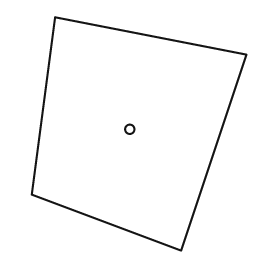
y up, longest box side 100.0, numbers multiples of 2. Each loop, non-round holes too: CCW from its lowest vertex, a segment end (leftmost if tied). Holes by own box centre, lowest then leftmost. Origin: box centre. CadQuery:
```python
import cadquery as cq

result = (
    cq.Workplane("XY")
    .moveTo(18.0, -50.0)
    .lineTo(46.0, 34.0)
    .lineTo(-36.0, 50.0)
    .lineTo(-46.0, -26.0)
    .close()
    .moveTo(-4.0, 2.0)
    .circle(2.0)
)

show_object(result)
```